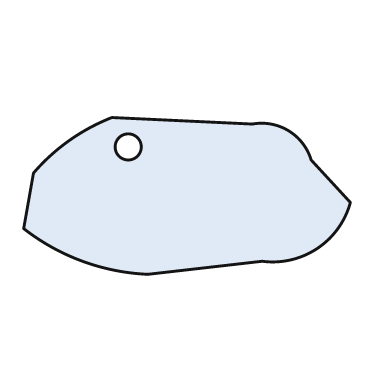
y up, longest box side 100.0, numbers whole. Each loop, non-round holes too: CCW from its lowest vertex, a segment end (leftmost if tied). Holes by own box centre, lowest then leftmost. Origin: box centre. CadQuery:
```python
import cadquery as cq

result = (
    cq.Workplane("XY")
    .moveTo(-12.0, -24.0)
    .lineTo(23.0, -20.0)
    .threePointArc((40.0, -16.0), (50.0, -2.0))
    .lineTo(38.0, 11.0)
    .threePointArc((31.0, 20.0), (20.0, 22.0))
    .lineTo(-23.0, 24.0)
    .threePointArc((-36.0, 17.0), (-47.0, 7.0))
    .lineTo(-50.0, -10.0)
    .threePointArc((-32.0, -20.0), (-12.0, -24.0))
    .close()
    .moveTo(-18.0, 15.0)
    .circle(4.0)
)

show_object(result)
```